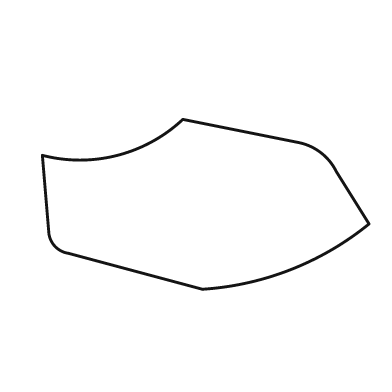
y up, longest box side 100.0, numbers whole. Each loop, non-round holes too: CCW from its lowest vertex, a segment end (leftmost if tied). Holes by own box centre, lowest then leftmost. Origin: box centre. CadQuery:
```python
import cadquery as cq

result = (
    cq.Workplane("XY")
    .moveTo(-1.0, -26.0)
    .threePointArc((26.0, -20.0), (50.0, -6.0))
    .lineTo(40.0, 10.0)
    .threePointArc((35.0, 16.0), (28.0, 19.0))
    .lineTo(-7.0, 26.0)
    .threePointArc((-27.0, 15.0), (-50.0, 15.0))
    .lineTo(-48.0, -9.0)
    .threePointArc((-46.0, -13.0), (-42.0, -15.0))
    .close()
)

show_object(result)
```